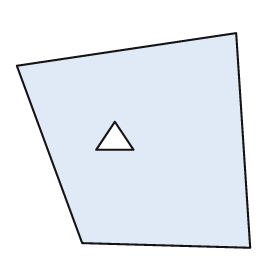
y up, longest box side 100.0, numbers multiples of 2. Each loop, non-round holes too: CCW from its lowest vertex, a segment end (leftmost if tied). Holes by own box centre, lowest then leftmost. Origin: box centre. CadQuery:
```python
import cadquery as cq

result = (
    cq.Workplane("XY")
    .moveTo(50.0, -46.0)
    .lineTo(44.0, 46.0)
    .lineTo(-50.0, 32.0)
    .lineTo(-22.0, -44.0)
    .close()
    .moveTo(-16.0, -4.0)
    .lineTo(0.0, -4.0)
    .lineTo(-8.0, 8.0)
    .close()
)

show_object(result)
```